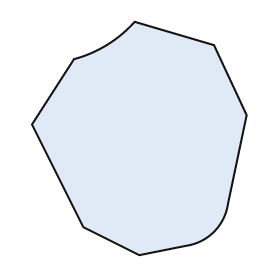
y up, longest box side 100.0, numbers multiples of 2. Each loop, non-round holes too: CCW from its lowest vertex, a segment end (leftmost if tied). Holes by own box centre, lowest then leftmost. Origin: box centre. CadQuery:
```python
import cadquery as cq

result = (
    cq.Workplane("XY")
    .moveTo(0.0, -50.0)
    .lineTo(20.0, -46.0)
    .threePointArc((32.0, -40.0), (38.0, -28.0))
    .lineTo(46.0, 10.0)
    .lineTo(32.0, 40.0)
    .lineTo(-2.0, 50.0)
    .threePointArc((-14.0, 40.0), (-28.0, 34.0))
    .lineTo(-46.0, 6.0)
    .lineTo(-24.0, -38.0)
    .close()
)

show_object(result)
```